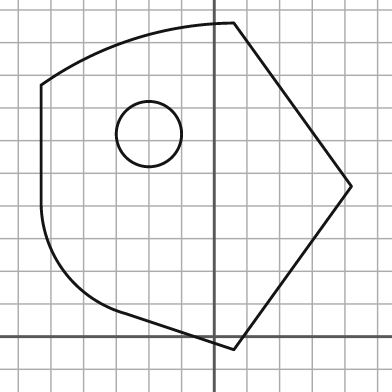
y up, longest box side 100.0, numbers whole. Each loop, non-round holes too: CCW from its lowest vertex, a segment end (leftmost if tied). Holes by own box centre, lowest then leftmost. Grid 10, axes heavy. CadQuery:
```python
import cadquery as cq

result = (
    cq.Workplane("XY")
    .moveTo(6.0, -4.0)
    .lineTo(42.0, 46.0)
    .lineTo(6.0, 96.0)
    .threePointArc((-25.0, 91.0), (-53.0, 77.0))
    .lineTo(-53.0, 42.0)
    .threePointArc((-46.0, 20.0), (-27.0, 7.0))
    .close()
    .moveTo(-20.0, 62.0)
    .circle(10.0)
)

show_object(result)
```